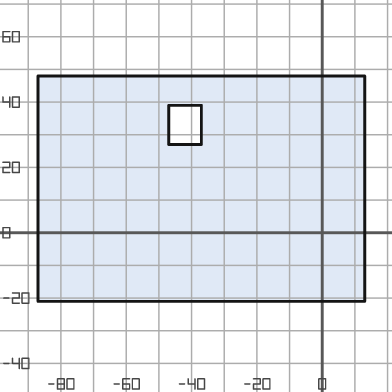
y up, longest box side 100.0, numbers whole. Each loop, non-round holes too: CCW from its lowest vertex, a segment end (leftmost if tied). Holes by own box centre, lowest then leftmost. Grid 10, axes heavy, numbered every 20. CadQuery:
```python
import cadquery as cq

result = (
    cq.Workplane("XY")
    .moveTo(-87.0, -21.0)
    .lineTo(13.0, -21.0)
    .lineTo(13.0, 48.0)
    .lineTo(-87.0, 48.0)
    .close()
    .moveTo(-47.0, 27.0)
    .lineTo(-37.0, 27.0)
    .lineTo(-37.0, 39.0)
    .lineTo(-47.0, 39.0)
    .close()
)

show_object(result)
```